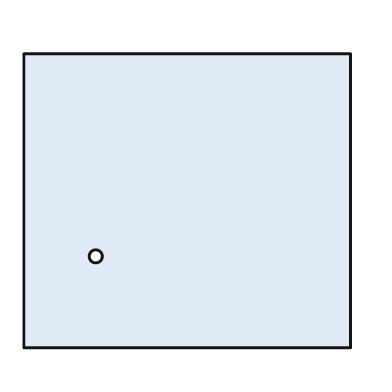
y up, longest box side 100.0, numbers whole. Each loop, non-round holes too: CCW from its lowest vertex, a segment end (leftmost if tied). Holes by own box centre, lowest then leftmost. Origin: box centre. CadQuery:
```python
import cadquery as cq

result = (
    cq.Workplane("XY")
    .moveTo(-50.0, -45.0)
    .lineTo(50.0, -45.0)
    .lineTo(50.0, 45.0)
    .lineTo(-50.0, 45.0)
    .close()
    .moveTo(-28.0, -17.0)
    .circle(2.0)
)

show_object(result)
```